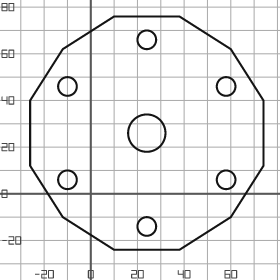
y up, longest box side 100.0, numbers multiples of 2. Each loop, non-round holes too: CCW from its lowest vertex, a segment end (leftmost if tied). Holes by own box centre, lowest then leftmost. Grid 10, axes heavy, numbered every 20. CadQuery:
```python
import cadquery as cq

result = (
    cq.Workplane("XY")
    .moveTo(10.0, -24.0)
    .lineTo(38.0, -24.0)
    .lineTo(60.0, -10.0)
    .lineTo(74.0, 12.0)
    .lineTo(74.0, 40.0)
    .lineTo(60.0, 62.0)
    .lineTo(38.0, 76.0)
    .lineTo(10.0, 76.0)
    .lineTo(-12.0, 62.0)
    .lineTo(-26.0, 40.0)
    .lineTo(-26.0, 12.0)
    .lineTo(-12.0, -10.0)
    .close()
    .moveTo(24.0, -14.0)
    .circle(4.0)
    .moveTo(-10.0, 6.0)
    .circle(4.0)
    .moveTo(58.0, 6.0)
    .circle(4.0)
    .moveTo(24.0, 26.0)
    .circle(8.0)
    .moveTo(-10.0, 46.0)
    .circle(4.0)
    .moveTo(58.0, 46.0)
    .circle(4.0)
    .moveTo(24.0, 66.0)
    .circle(4.0)
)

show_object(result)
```